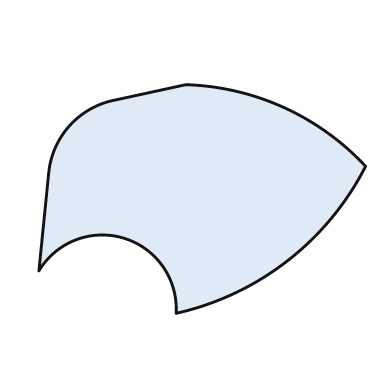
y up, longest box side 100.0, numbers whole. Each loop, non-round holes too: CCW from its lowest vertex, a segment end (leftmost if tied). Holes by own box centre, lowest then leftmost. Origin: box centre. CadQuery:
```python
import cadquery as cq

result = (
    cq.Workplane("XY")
    .moveTo(-8.0, -35.0)
    .threePointArc((26.0, -19.0), (50.0, 10.0))
    .threePointArc((25.0, 28.0), (-5.0, 35.0))
    .lineTo(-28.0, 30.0)
    .threePointArc((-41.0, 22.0), (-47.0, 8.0))
    .lineTo(-50.0, -22.0)
    .threePointArc((-24.0, -12.0), (-8.0, -35.0))
    .close()
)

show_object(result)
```